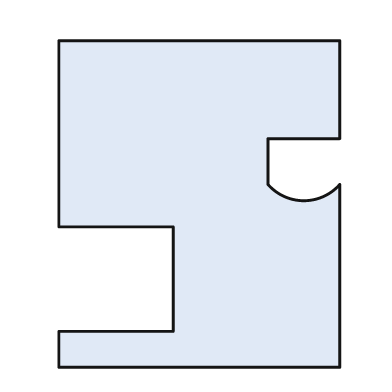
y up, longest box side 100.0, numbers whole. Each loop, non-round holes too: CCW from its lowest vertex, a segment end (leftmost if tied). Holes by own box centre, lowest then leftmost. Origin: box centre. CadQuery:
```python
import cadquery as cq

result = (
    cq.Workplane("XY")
    .moveTo(-43.0, -50.0)
    .lineTo(43.0, -50.0)
    .lineTo(43.0, 6.0)
    .threePointArc((32.0, 1.0), (21.0, 6.0))
    .lineTo(21.0, 20.0)
    .lineTo(43.0, 20.0)
    .lineTo(43.0, 50.0)
    .lineTo(-43.0, 50.0)
    .lineTo(-43.0, -7.0)
    .lineTo(-8.0, -7.0)
    .lineTo(-8.0, -39.0)
    .lineTo(-43.0, -39.0)
    .close()
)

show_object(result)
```